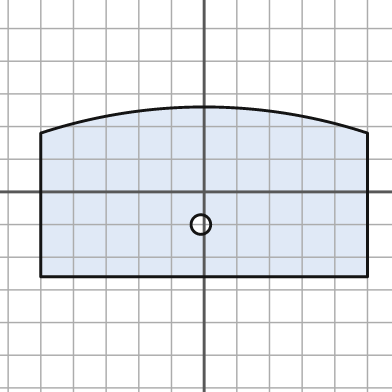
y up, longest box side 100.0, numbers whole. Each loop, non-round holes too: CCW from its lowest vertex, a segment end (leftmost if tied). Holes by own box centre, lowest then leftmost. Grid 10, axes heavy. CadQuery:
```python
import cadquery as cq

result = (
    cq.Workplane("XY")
    .moveTo(-50.0, -26.0)
    .lineTo(50.0, -26.0)
    .lineTo(50.0, 18.0)
    .threePointArc((0.0, 26.0), (-50.0, 18.0))
    .close()
    .moveTo(-1.0, -10.0)
    .circle(3.0)
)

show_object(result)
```